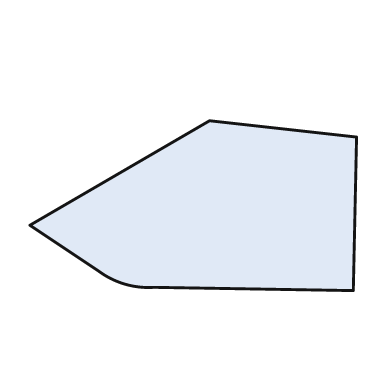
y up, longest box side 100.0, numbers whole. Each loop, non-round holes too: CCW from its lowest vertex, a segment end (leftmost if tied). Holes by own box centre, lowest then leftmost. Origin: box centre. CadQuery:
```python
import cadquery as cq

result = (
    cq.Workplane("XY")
    .moveTo(49.0, -26.0)
    .lineTo(50.0, 21.0)
    .lineTo(5.0, 26.0)
    .lineTo(-50.0, -6.0)
    .lineTo(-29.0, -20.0)
    .threePointArc((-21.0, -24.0), (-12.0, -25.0))
    .close()
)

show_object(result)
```